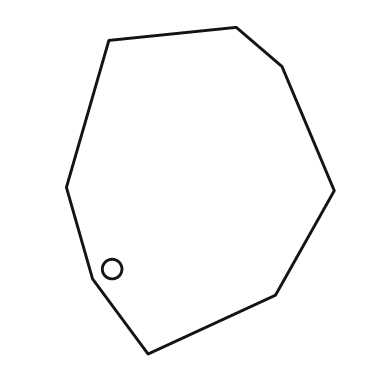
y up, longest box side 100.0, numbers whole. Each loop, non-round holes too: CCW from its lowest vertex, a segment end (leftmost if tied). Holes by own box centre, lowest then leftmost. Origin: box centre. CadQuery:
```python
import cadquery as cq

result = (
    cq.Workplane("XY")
    .moveTo(-16.0, -50.0)
    .lineTo(23.0, -32.0)
    .lineTo(41.0, 0.0)
    .lineTo(25.0, 38.0)
    .lineTo(11.0, 50.0)
    .lineTo(-28.0, 46.0)
    .lineTo(-41.0, 1.0)
    .lineTo(-33.0, -27.0)
    .close()
    .moveTo(-27.0, -24.0)
    .circle(3.0)
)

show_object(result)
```